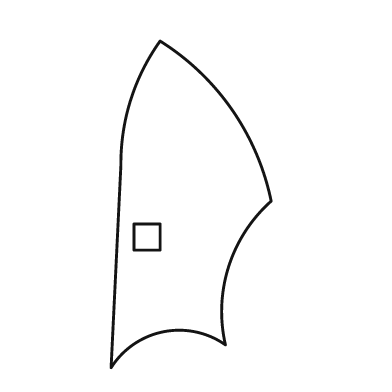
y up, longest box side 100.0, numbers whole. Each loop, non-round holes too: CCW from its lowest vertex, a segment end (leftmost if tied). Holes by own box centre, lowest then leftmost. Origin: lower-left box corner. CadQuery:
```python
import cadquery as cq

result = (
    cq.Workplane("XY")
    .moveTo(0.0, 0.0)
    .threePointArc((16.0, 11.0), (35.0, 7.0))
    .threePointArc((36.0, 31.0), (49.0, 51.0))
    .threePointArc((37.0, 79.0), (15.0, 100.0))
    .threePointArc((6.0, 82.0), (3.0, 62.0))
    .close()
    .moveTo(7.0, 36.0)
    .lineTo(15.0, 36.0)
    .lineTo(15.0, 44.0)
    .lineTo(7.0, 44.0)
    .close()
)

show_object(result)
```